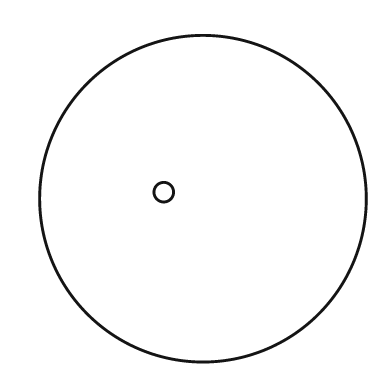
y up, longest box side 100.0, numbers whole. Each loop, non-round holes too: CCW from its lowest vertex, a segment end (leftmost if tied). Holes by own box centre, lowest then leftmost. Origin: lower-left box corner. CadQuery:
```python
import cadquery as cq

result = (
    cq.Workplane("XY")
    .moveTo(50.0, 50.0)
    .circle(50.0)
    .moveTo(38.0, 52.0)
    .circle(3.0)
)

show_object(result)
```